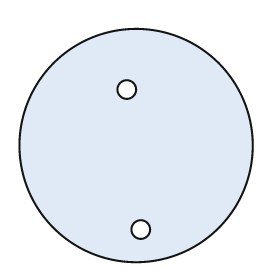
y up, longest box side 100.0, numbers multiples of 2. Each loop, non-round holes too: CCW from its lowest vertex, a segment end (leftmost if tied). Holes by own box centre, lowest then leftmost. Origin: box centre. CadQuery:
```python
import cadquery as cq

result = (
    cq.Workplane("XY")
    .moveTo(0.0, 0.0)
    .circle(50.0)
    .moveTo(2.0, -36.0)
    .circle(4.0)
    .moveTo(-4.0, 24.0)
    .circle(4.0)
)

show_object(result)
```